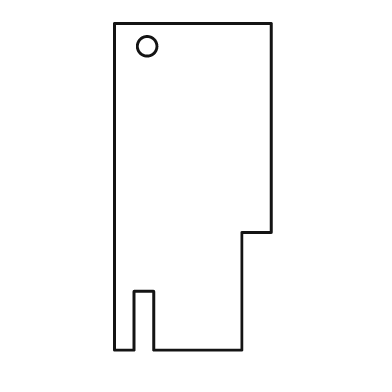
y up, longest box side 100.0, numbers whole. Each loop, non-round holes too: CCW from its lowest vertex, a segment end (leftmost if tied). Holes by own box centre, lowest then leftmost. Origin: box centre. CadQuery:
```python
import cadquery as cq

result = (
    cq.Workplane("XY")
    .moveTo(-24.0, -50.0)
    .lineTo(-18.0, -50.0)
    .lineTo(-18.0, -32.0)
    .lineTo(-12.0, -32.0)
    .lineTo(-12.0, -50.0)
    .lineTo(15.0, -50.0)
    .lineTo(15.0, -14.0)
    .lineTo(24.0, -14.0)
    .lineTo(24.0, 50.0)
    .lineTo(-24.0, 50.0)
    .close()
    .moveTo(-14.0, 43.0)
    .circle(3.0)
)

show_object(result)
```